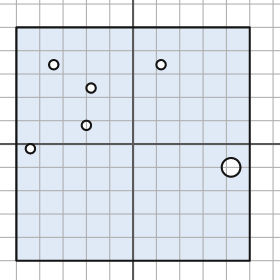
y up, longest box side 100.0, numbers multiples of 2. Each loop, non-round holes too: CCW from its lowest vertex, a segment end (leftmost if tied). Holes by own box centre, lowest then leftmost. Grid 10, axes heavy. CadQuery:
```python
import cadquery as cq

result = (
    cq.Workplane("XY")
    .moveTo(-50.0, -50.0)
    .lineTo(50.0, -50.0)
    .lineTo(50.0, 50.0)
    .lineTo(-50.0, 50.0)
    .close()
    .moveTo(42.0, -10.0)
    .circle(4.0)
    .moveTo(-44.0, -2.0)
    .circle(2.0)
    .moveTo(-20.0, 8.0)
    .circle(2.0)
    .moveTo(-18.0, 24.0)
    .circle(2.0)
    .moveTo(-34.0, 34.0)
    .circle(2.0)
    .moveTo(12.0, 34.0)
    .circle(2.0)
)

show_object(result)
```